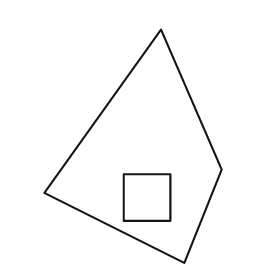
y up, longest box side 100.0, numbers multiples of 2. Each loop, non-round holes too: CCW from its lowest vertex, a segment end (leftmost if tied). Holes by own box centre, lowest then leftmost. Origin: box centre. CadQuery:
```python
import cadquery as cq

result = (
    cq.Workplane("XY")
    .moveTo(22.0, -50.0)
    .lineTo(38.0, -10.0)
    .lineTo(12.0, 50.0)
    .lineTo(-38.0, -20.0)
    .close()
    .moveTo(-4.0, -32.0)
    .lineTo(16.0, -32.0)
    .lineTo(16.0, -12.0)
    .lineTo(-4.0, -12.0)
    .close()
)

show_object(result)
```